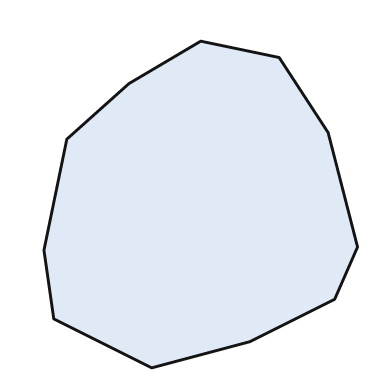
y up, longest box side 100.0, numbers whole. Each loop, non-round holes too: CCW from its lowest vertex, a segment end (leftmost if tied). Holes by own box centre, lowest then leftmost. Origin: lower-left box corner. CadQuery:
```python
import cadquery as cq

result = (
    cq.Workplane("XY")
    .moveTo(33.0, 0.0)
    .lineTo(63.0, 8.0)
    .lineTo(89.0, 21.0)
    .lineTo(96.0, 37.0)
    .lineTo(87.0, 72.0)
    .lineTo(72.0, 95.0)
    .lineTo(48.0, 100.0)
    .lineTo(26.0, 87.0)
    .lineTo(7.0, 70.0)
    .lineTo(0.0, 36.0)
    .lineTo(3.0, 15.0)
    .close()
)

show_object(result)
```